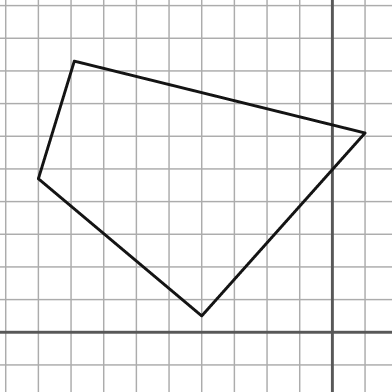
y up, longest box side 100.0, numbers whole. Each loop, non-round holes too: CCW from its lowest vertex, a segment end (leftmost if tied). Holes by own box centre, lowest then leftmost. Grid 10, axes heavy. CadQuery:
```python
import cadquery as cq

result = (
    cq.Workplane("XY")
    .moveTo(-40.0, 5.0)
    .lineTo(10.0, 61.0)
    .lineTo(-79.0, 83.0)
    .lineTo(-90.0, 47.0)
    .close()
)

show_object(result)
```